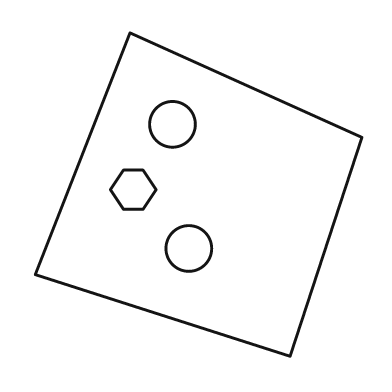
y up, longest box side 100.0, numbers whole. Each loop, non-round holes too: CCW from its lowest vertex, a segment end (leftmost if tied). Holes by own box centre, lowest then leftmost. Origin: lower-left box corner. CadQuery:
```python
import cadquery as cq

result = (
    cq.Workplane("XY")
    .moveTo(78.0, 0.0)
    .lineTo(100.0, 67.0)
    .lineTo(29.0, 99.0)
    .lineTo(0.0, 25.0)
    .close()
    .moveTo(47.0, 33.0)
    .circle(7.0)
    .moveTo(27.0, 45.0)
    .lineTo(33.0, 45.0)
    .lineTo(37.0, 51.0)
    .lineTo(33.0, 57.0)
    .lineTo(27.0, 57.0)
    .lineTo(23.0, 51.0)
    .close()
    .moveTo(42.0, 71.0)
    .circle(7.0)
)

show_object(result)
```